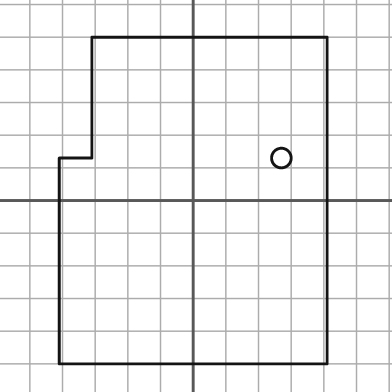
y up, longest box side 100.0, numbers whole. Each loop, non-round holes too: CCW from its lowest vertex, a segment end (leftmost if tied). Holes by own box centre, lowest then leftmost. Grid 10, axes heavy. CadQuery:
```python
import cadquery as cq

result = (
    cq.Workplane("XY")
    .moveTo(-41.0, -50.0)
    .lineTo(41.0, -50.0)
    .lineTo(41.0, 50.0)
    .lineTo(-31.0, 50.0)
    .lineTo(-31.0, 13.0)
    .lineTo(-41.0, 13.0)
    .close()
    .moveTo(27.0, 13.0)
    .circle(3.0)
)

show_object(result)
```